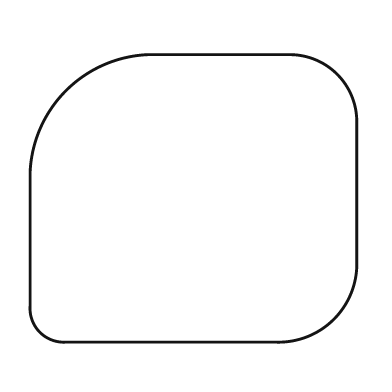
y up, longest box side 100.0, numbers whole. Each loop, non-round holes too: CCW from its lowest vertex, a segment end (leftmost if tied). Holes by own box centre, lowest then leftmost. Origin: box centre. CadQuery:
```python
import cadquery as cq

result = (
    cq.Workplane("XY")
    .moveTo(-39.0, -44.0)
    .lineTo(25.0, -44.0)
    .threePointArc((43.0, -37.0), (50.0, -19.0))
    .lineTo(50.0, 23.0)
    .threePointArc((44.0, 38.0), (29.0, 44.0))
    .lineTo(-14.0, 44.0)
    .threePointArc((-39.0, 33.0), (-50.0, 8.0))
    .lineTo(-50.0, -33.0)
    .threePointArc((-47.0, -41.0), (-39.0, -44.0))
    .close()
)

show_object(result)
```